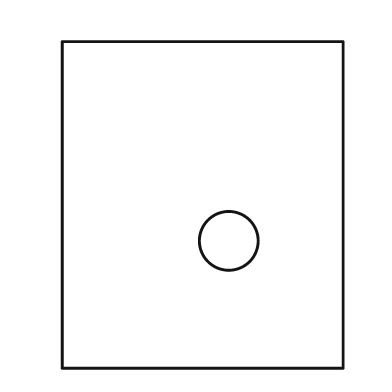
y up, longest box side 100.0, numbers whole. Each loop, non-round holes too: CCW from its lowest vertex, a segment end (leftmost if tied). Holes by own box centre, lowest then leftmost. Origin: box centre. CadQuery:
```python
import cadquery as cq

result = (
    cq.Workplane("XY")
    .moveTo(-43.0, -50.0)
    .lineTo(43.0, -50.0)
    .lineTo(43.0, 50.0)
    .lineTo(-43.0, 50.0)
    .close()
    .moveTo(8.0, -11.0)
    .circle(9.0)
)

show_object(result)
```